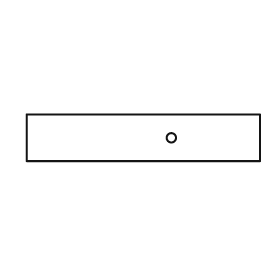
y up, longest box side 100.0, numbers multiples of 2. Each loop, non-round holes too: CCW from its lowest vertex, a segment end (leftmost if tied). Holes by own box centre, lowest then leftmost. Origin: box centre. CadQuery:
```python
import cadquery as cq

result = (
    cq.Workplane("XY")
    .moveTo(-50.0, -10.0)
    .lineTo(50.0, -10.0)
    .lineTo(50.0, 10.0)
    .lineTo(-50.0, 10.0)
    .close()
    .moveTo(12.0, 0.0)
    .circle(2.0)
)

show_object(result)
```